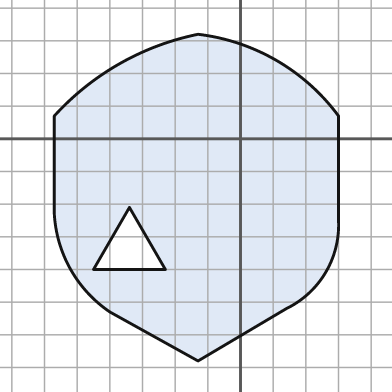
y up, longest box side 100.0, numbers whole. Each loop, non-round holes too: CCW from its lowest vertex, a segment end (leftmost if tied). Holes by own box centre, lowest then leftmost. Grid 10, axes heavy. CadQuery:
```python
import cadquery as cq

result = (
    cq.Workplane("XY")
    .moveTo(-13.0, -68.0)
    .lineTo(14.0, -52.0)
    .threePointArc((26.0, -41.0), (30.0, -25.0))
    .lineTo(30.0, 7.0)
    .threePointArc((11.0, 24.0), (-13.0, 32.0))
    .threePointArc((-37.0, 23.0), (-57.0, 7.0))
    .lineTo(-57.0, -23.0)
    .threePointArc((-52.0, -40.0), (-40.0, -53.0))
    .close()
    .moveTo(-45.0, -40.0)
    .lineTo(-23.0, -40.0)
    .lineTo(-34.0, -21.0)
    .close()
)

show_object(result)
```